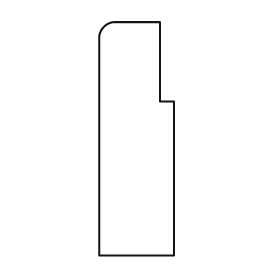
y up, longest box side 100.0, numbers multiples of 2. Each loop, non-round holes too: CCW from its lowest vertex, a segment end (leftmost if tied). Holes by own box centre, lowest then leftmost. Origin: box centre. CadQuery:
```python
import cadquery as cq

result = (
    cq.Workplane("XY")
    .moveTo(-16.0, -50.0)
    .lineTo(16.0, -50.0)
    .lineTo(16.0, 16.0)
    .lineTo(10.0, 16.0)
    .lineTo(10.0, 50.0)
    .lineTo(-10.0, 50.0)
    .threePointArc((-14.0, 48.0), (-16.0, 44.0))
    .close()
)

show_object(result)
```